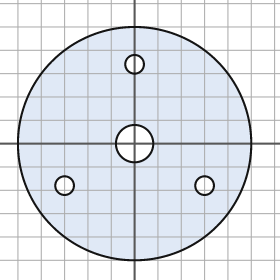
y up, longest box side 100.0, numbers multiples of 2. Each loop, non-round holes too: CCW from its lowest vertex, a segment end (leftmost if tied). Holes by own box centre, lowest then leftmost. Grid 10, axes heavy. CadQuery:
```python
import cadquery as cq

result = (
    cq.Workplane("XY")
    .moveTo(0.0, 0.0)
    .circle(50.0)
    .moveTo(-30.0, -18.0)
    .circle(4.0)
    .moveTo(30.0, -18.0)
    .circle(4.0)
    .moveTo(0.0, 0.0)
    .circle(8.0)
    .moveTo(0.0, 34.0)
    .circle(4.0)
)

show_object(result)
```